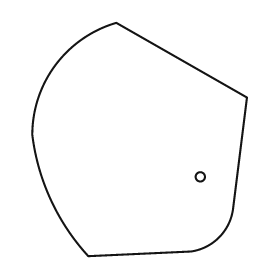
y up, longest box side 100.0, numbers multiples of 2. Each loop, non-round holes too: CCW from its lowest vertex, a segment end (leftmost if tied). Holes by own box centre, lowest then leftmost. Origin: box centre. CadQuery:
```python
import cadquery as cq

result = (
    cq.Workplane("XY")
    .moveTo(-22.0, -50.0)
    .lineTo(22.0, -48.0)
    .threePointArc((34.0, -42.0), (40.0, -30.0))
    .lineTo(46.0, 18.0)
    .lineTo(-10.0, 50.0)
    .threePointArc((-36.0, 32.0), (-46.0, 2.0))
    .threePointArc((-38.0, -26.0), (-22.0, -50.0))
    .close()
    .moveTo(26.0, -16.0)
    .circle(2.0)
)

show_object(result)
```